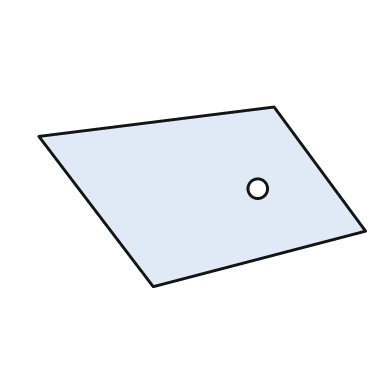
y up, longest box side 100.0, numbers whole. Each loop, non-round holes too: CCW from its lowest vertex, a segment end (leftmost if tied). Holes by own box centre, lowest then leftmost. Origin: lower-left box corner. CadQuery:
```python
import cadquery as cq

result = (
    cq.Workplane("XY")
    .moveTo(35.0, 0.0)
    .lineTo(100.0, 17.0)
    .lineTo(72.0, 55.0)
    .lineTo(0.0, 46.0)
    .close()
    .moveTo(67.0, 30.0)
    .circle(3.0)
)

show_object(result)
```